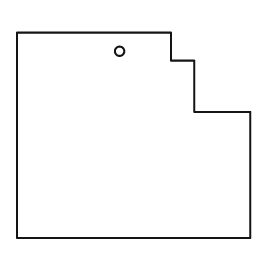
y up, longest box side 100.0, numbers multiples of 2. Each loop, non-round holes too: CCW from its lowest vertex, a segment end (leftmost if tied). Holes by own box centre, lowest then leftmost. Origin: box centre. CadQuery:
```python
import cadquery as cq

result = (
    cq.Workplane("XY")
    .moveTo(-50.0, -44.0)
    .lineTo(50.0, -44.0)
    .lineTo(50.0, 10.0)
    .lineTo(26.0, 10.0)
    .lineTo(26.0, 32.0)
    .lineTo(16.0, 32.0)
    .lineTo(16.0, 44.0)
    .lineTo(-50.0, 44.0)
    .close()
    .moveTo(-6.0, 36.0)
    .circle(2.0)
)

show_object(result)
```